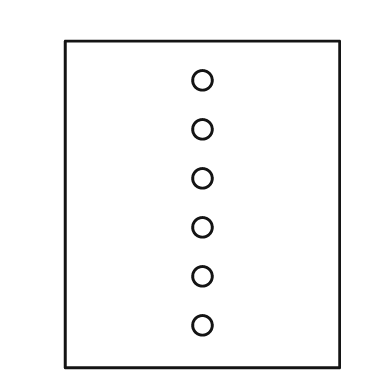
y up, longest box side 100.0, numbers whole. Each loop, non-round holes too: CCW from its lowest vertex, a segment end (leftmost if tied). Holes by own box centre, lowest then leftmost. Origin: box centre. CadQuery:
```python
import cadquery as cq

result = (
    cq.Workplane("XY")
    .moveTo(-42.0, -50.0)
    .lineTo(42.0, -50.0)
    .lineTo(42.0, 50.0)
    .lineTo(-42.0, 50.0)
    .close()
    .moveTo(0.0, -37.0)
    .circle(3.0)
    .moveTo(0.0, -22.0)
    .circle(3.0)
    .moveTo(0.0, -7.0)
    .circle(3.0)
    .moveTo(0.0, 8.0)
    .circle(3.0)
    .moveTo(0.0, 23.0)
    .circle(3.0)
    .moveTo(0.0, 38.0)
    .circle(3.0)
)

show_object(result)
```